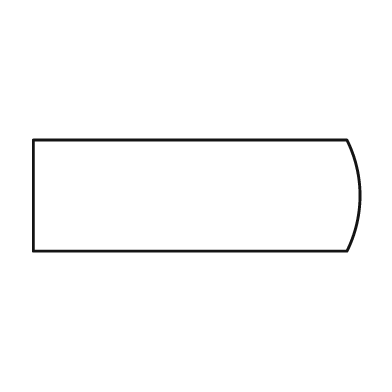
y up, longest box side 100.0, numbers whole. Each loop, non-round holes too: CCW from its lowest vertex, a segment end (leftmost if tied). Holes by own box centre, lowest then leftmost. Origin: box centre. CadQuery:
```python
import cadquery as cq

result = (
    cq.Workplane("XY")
    .moveTo(-50.0, -17.0)
    .lineTo(46.0, -17.0)
    .threePointArc((50.0, 0.0), (46.0, 17.0))
    .lineTo(-50.0, 17.0)
    .close()
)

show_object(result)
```